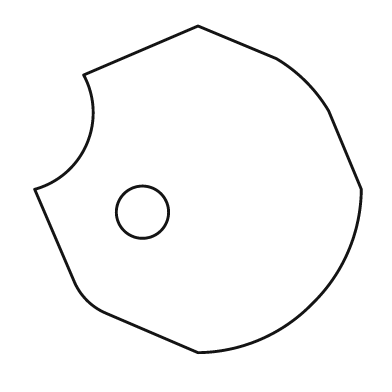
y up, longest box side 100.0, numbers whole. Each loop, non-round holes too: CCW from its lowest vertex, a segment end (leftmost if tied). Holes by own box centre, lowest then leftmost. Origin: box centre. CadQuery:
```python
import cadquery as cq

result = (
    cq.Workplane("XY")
    .moveTo(0.0, -50.0)
    .threePointArc((19.0, -46.0), (35.0, -35.0))
    .threePointArc((46.0, -19.0), (50.0, 0.0))
    .lineTo(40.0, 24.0)
    .threePointArc((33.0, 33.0), (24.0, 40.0))
    .lineTo(0.0, 50.0)
    .lineTo(-35.0, 35.0)
    .threePointArc((-34.0, 14.0), (-50.0, 0.0))
    .lineTo(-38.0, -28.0)
    .threePointArc((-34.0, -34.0), (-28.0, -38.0))
    .close()
    .moveTo(-17.0, -7.0)
    .circle(8.0)
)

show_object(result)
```